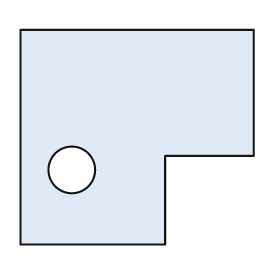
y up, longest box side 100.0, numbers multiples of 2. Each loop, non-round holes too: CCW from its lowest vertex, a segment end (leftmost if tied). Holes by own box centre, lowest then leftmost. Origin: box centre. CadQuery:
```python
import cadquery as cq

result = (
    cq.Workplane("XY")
    .moveTo(-50.0, -46.0)
    .lineTo(12.0, -46.0)
    .lineTo(12.0, -8.0)
    .lineTo(50.0, -8.0)
    .lineTo(50.0, 46.0)
    .lineTo(-50.0, 46.0)
    .close()
    .moveTo(-28.0, -14.0)
    .circle(10.0)
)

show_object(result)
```